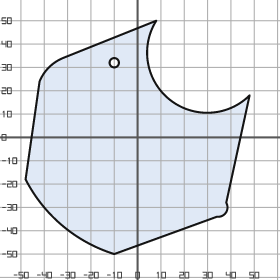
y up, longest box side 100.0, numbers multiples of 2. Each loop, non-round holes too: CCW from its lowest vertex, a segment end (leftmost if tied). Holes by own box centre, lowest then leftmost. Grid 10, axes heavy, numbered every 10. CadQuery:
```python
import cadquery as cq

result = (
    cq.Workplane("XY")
    .moveTo(-10.0, -50.0)
    .lineTo(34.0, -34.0)
    .threePointArc((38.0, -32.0), (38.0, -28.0))
    .lineTo(48.0, 18.0)
    .threePointArc((14.0, 16.0), (8.0, 50.0))
    .lineTo(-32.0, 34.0)
    .threePointArc((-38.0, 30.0), (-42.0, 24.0))
    .lineTo(-48.0, -18.0)
    .threePointArc((-32.0, -38.0), (-10.0, -50.0))
    .close()
    .moveTo(-10.0, 32.0)
    .circle(2.0)
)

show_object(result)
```